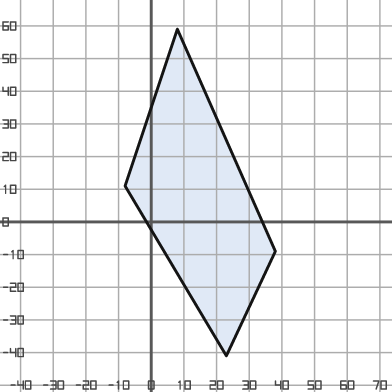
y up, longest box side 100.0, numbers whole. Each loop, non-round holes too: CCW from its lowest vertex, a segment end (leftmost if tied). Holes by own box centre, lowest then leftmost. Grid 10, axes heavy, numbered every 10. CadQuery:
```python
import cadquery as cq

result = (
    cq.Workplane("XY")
    .moveTo(23.0, -41.0)
    .lineTo(38.0, -9.0)
    .lineTo(8.0, 59.0)
    .lineTo(-8.0, 11.0)
    .close()
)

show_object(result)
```